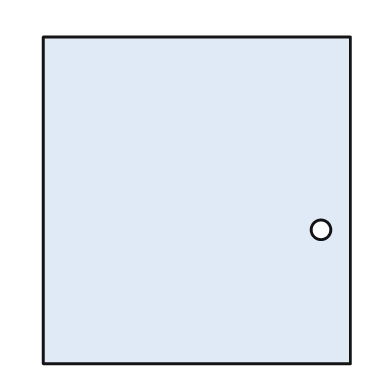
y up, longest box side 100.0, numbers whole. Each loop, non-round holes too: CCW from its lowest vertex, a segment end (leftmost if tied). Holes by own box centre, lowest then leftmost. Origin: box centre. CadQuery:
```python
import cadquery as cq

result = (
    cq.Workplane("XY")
    .moveTo(-47.0, -50.0)
    .lineTo(47.0, -50.0)
    .lineTo(47.0, 50.0)
    .lineTo(-47.0, 50.0)
    .close()
    .moveTo(38.0, -9.0)
    .circle(3.0)
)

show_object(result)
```